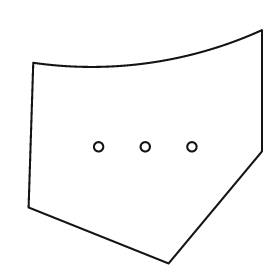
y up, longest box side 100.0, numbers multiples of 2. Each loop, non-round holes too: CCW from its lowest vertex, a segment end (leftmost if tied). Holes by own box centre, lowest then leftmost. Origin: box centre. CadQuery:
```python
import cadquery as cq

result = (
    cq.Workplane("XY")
    .moveTo(10.0, -50.0)
    .lineTo(50.0, -2.0)
    .lineTo(50.0, 50.0)
    .threePointArc((2.0, 36.0), (-48.0, 36.0))
    .lineTo(-50.0, -26.0)
    .close()
    .moveTo(-20.0, 0.0)
    .circle(2.0)
    .moveTo(0.0, 0.0)
    .circle(2.0)
    .moveTo(20.0, 0.0)
    .circle(2.0)
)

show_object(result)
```